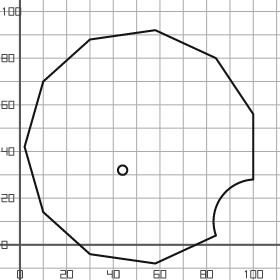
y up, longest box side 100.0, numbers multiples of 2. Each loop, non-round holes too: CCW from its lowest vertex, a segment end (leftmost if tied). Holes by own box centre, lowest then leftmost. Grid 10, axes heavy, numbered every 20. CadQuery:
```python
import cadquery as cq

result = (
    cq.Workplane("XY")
    .moveTo(58.0, -8.0)
    .lineTo(84.0, 4.0)
    .threePointArc((86.0, 20.0), (100.0, 28.0))
    .lineTo(100.0, 56.0)
    .lineTo(84.0, 80.0)
    .lineTo(58.0, 92.0)
    .lineTo(30.0, 88.0)
    .lineTo(10.0, 70.0)
    .lineTo(2.0, 42.0)
    .lineTo(10.0, 14.0)
    .lineTo(30.0, -4.0)
    .close()
    .moveTo(44.0, 32.0)
    .circle(2.0)
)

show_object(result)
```